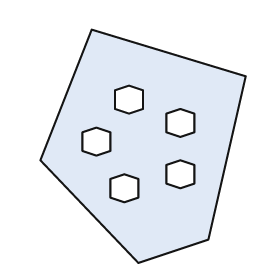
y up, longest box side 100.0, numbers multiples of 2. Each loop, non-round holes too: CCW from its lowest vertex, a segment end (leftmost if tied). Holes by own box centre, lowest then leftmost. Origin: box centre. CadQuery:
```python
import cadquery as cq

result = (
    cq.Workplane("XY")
    .moveTo(-2.0, -50.0)
    .lineTo(28.0, -40.0)
    .lineTo(44.0, 30.0)
    .lineTo(-22.0, 50.0)
    .lineTo(-44.0, -6.0)
    .close()
    .moveTo(-8.0, -24.0)
    .lineTo(-2.0, -22.0)
    .lineTo(-2.0, -14.0)
    .lineTo(-8.0, -12.0)
    .lineTo(-14.0, -14.0)
    .lineTo(-14.0, -22.0)
    .close()
    .moveTo(16.0, -18.0)
    .lineTo(22.0, -16.0)
    .lineTo(22.0, -8.0)
    .lineTo(16.0, -6.0)
    .lineTo(10.0, -8.0)
    .lineTo(10.0, -16.0)
    .close()
    .moveTo(-20.0, -4.0)
    .lineTo(-14.0, -2.0)
    .lineTo(-14.0, 6.0)
    .lineTo(-20.0, 8.0)
    .lineTo(-26.0, 6.0)
    .lineTo(-26.0, -2.0)
    .close()
    .moveTo(16.0, 4.0)
    .lineTo(22.0, 6.0)
    .lineTo(22.0, 14.0)
    .lineTo(16.0, 16.0)
    .lineTo(10.0, 14.0)
    .lineTo(10.0, 6.0)
    .close()
    .moveTo(-6.0, 14.0)
    .lineTo(0.0, 16.0)
    .lineTo(0.0, 24.0)
    .lineTo(-6.0, 26.0)
    .lineTo(-12.0, 24.0)
    .lineTo(-12.0, 16.0)
    .close()
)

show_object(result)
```